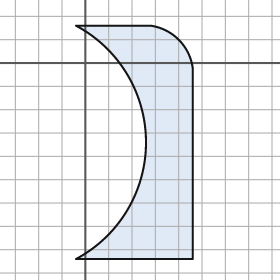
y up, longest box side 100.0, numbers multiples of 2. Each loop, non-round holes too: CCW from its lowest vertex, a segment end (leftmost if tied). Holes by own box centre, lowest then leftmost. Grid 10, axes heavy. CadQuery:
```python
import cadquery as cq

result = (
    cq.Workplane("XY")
    .moveTo(-4.0, -84.0)
    .lineTo(46.0, -84.0)
    .lineTo(46.0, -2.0)
    .threePointArc((40.0, 10.0), (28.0, 16.0))
    .lineTo(-4.0, 16.0)
    .threePointArc((26.0, -34.0), (-4.0, -84.0))
    .close()
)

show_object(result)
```